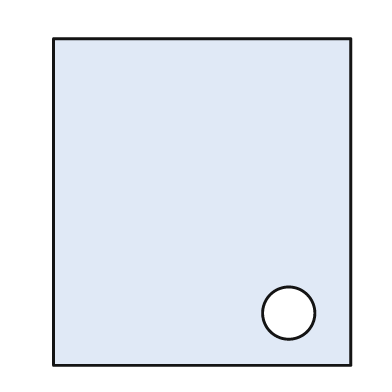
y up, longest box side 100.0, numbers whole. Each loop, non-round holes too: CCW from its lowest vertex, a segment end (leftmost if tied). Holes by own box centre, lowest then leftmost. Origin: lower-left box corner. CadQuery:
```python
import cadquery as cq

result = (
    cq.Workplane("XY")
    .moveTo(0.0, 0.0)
    .lineTo(91.0, 0.0)
    .lineTo(91.0, 100.0)
    .lineTo(0.0, 100.0)
    .close()
    .moveTo(72.0, 16.0)
    .circle(8.0)
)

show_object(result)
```